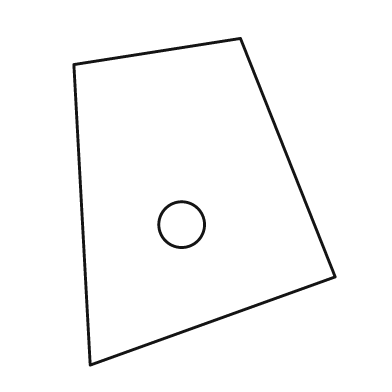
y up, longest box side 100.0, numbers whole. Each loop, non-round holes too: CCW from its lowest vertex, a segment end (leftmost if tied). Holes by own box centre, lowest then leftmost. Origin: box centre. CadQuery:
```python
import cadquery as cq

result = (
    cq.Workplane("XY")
    .moveTo(-35.0, -50.0)
    .lineTo(40.0, -23.0)
    .lineTo(11.0, 50.0)
    .lineTo(-40.0, 42.0)
    .close()
    .moveTo(-7.0, -7.0)
    .circle(7.0)
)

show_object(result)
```